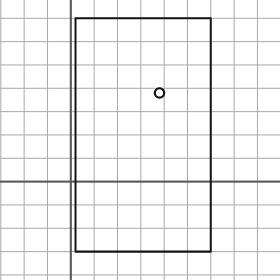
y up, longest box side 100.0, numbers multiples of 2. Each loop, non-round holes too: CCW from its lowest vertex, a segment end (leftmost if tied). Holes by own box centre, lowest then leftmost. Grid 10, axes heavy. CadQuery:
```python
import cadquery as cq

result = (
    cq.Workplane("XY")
    .moveTo(2.0, -30.0)
    .lineTo(60.0, -30.0)
    .lineTo(60.0, 70.0)
    .lineTo(2.0, 70.0)
    .close()
    .moveTo(38.0, 38.0)
    .circle(2.0)
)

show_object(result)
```